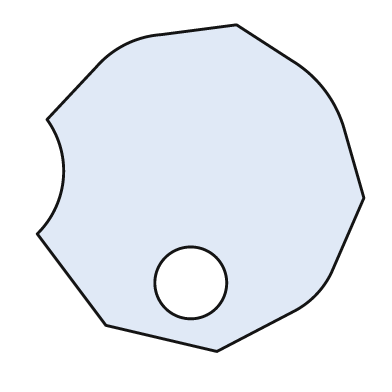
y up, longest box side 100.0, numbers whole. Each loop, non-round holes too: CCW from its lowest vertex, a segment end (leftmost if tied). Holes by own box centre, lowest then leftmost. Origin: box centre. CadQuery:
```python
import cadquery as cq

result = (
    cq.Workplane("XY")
    .moveTo(5.0, -50.0)
    .lineTo(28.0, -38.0)
    .threePointArc((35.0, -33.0), (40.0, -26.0))
    .lineTo(50.0, -3.0)
    .lineTo(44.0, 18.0)
    .threePointArc((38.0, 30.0), (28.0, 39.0))
    .lineTo(11.0, 50.0)
    .lineTo(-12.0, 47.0)
    .threePointArc((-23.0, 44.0), (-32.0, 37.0))
    .lineTo(-47.0, 21.0)
    .threePointArc((-42.0, 3.0), (-50.0, -14.0))
    .lineTo(-29.0, -42.0)
    .close()
    .moveTo(-3.0, -29.0)
    .circle(11.0)
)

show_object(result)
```